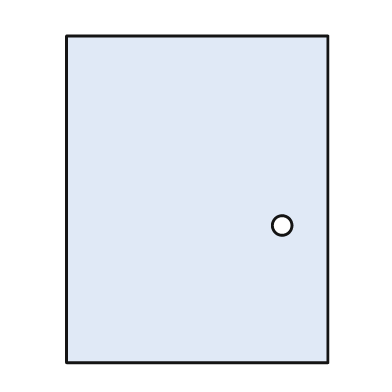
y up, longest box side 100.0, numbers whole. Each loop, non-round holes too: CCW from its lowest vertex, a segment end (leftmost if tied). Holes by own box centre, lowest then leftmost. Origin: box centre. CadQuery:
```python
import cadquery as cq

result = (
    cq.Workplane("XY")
    .moveTo(-40.0, -50.0)
    .lineTo(40.0, -50.0)
    .lineTo(40.0, 50.0)
    .lineTo(-40.0, 50.0)
    .close()
    .moveTo(26.0, -8.0)
    .circle(3.0)
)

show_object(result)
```